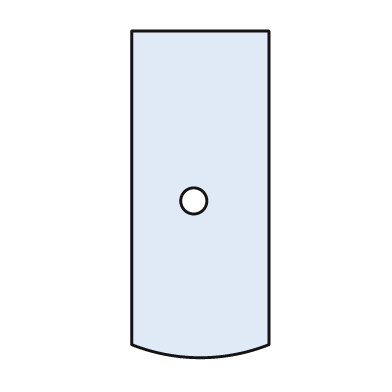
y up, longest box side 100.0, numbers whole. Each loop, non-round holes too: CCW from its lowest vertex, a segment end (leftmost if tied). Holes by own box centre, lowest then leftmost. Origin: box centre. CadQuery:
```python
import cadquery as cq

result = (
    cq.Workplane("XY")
    .moveTo(-21.0, -46.0)
    .threePointArc((0.0, -50.0), (21.0, -46.0))
    .lineTo(21.0, 50.0)
    .lineTo(-21.0, 50.0)
    .close()
    .moveTo(-2.0, -2.0)
    .circle(4.0)
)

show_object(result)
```